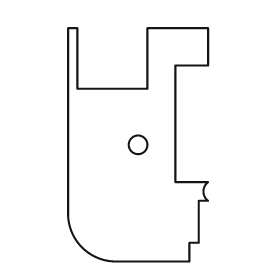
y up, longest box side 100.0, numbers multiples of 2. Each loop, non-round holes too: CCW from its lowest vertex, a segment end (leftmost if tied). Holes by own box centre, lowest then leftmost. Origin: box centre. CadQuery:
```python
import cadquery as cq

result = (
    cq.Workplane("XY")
    .moveTo(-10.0, -50.0)
    .lineTo(22.0, -50.0)
    .lineTo(22.0, -42.0)
    .lineTo(26.0, -42.0)
    .lineTo(26.0, -24.0)
    .lineTo(30.0, -24.0)
    .threePointArc((28.0, -20.0), (30.0, -16.0))
    .lineTo(16.0, -16.0)
    .lineTo(16.0, 34.0)
    .lineTo(30.0, 34.0)
    .lineTo(30.0, 50.0)
    .lineTo(4.0, 50.0)
    .lineTo(4.0, 24.0)
    .lineTo(-26.0, 24.0)
    .lineTo(-26.0, 50.0)
    .lineTo(-30.0, 50.0)
    .lineTo(-30.0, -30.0)
    .threePointArc((-24.0, -44.0), (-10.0, -50.0))
    .close()
    .moveTo(0.0, 0.0)
    .circle(4.0)
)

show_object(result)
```